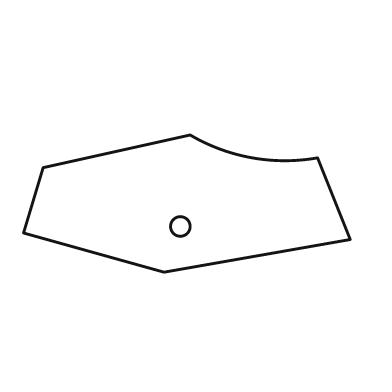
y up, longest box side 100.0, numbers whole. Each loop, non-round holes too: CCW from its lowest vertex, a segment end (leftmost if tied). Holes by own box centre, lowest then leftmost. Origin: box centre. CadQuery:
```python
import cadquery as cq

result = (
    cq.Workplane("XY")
    .moveTo(-7.0, -21.0)
    .lineTo(50.0, -11.0)
    .lineTo(40.0, 14.0)
    .threePointArc((20.0, 14.0), (1.0, 21.0))
    .lineTo(-44.0, 11.0)
    .lineTo(-50.0, -9.0)
    .close()
    .moveTo(-2.0, -7.0)
    .circle(3.0)
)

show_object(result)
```